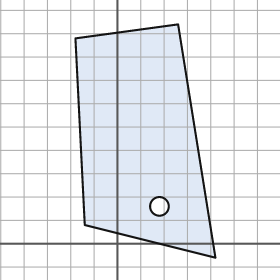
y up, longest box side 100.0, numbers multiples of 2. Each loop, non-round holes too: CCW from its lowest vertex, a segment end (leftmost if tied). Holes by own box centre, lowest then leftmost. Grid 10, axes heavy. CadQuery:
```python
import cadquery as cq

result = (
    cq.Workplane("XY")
    .moveTo(42.0, -6.0)
    .lineTo(26.0, 94.0)
    .lineTo(-18.0, 88.0)
    .lineTo(-14.0, 8.0)
    .close()
    .moveTo(18.0, 16.0)
    .circle(4.0)
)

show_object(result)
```